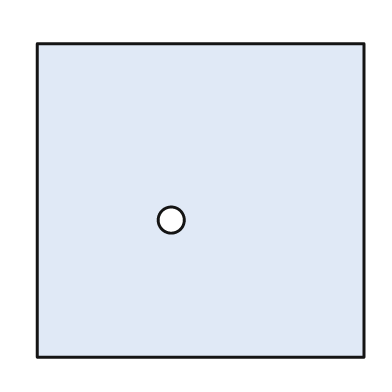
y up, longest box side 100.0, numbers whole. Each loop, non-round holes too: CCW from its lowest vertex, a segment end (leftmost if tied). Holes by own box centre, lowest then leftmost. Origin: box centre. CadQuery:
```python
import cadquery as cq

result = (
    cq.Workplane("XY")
    .moveTo(-50.0, -48.0)
    .lineTo(50.0, -48.0)
    .lineTo(50.0, 48.0)
    .lineTo(-50.0, 48.0)
    .close()
    .moveTo(-9.0, -6.0)
    .circle(4.0)
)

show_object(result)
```